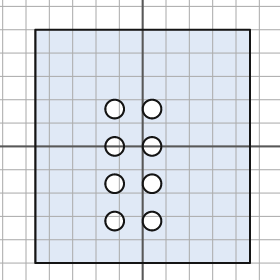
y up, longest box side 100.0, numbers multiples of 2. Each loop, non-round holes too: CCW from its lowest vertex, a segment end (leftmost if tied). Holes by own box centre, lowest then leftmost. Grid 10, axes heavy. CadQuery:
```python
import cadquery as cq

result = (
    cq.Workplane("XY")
    .moveTo(-46.0, -50.0)
    .lineTo(46.0, -50.0)
    .lineTo(46.0, 50.0)
    .lineTo(-46.0, 50.0)
    .close()
    .moveTo(-12.0, -32.0)
    .circle(4.0)
    .moveTo(4.0, -32.0)
    .circle(4.0)
    .moveTo(-12.0, -16.0)
    .circle(4.0)
    .moveTo(4.0, -16.0)
    .circle(4.0)
    .moveTo(-12.0, 0.0)
    .circle(4.0)
    .moveTo(4.0, 0.0)
    .circle(4.0)
    .moveTo(-12.0, 16.0)
    .circle(4.0)
    .moveTo(4.0, 16.0)
    .circle(4.0)
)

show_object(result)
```